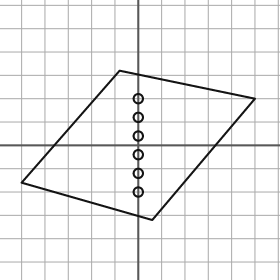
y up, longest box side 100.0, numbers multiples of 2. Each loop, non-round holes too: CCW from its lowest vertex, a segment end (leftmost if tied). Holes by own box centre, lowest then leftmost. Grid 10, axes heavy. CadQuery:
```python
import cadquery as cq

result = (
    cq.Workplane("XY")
    .moveTo(6.0, -32.0)
    .lineTo(50.0, 20.0)
    .lineTo(-8.0, 32.0)
    .lineTo(-50.0, -16.0)
    .close()
    .moveTo(0.0, -20.0)
    .circle(2.0)
    .moveTo(0.0, -12.0)
    .circle(2.0)
    .moveTo(0.0, -4.0)
    .circle(2.0)
    .moveTo(0.0, 4.0)
    .circle(2.0)
    .moveTo(0.0, 12.0)
    .circle(2.0)
    .moveTo(0.0, 20.0)
    .circle(2.0)
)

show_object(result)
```